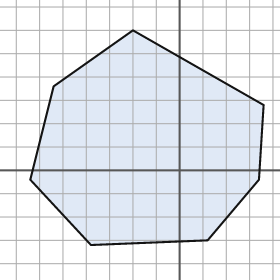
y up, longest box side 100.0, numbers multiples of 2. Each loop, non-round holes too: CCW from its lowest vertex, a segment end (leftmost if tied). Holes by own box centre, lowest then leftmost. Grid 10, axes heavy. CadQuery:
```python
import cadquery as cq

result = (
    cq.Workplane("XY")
    .moveTo(-38.0, -32.0)
    .lineTo(12.0, -30.0)
    .lineTo(34.0, -4.0)
    .lineTo(36.0, 28.0)
    .lineTo(-20.0, 60.0)
    .lineTo(-54.0, 36.0)
    .lineTo(-64.0, -4.0)
    .close()
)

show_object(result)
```